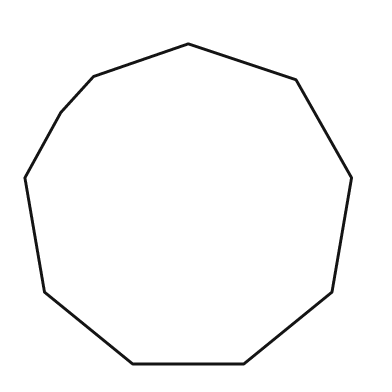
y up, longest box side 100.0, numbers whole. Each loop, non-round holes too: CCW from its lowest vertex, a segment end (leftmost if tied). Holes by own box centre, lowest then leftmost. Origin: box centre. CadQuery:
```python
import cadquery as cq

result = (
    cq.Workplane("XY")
    .moveTo(-17.0, -49.0)
    .lineTo(17.0, -49.0)
    .lineTo(44.0, -27.0)
    .lineTo(50.0, 8.0)
    .lineTo(33.0, 38.0)
    .lineTo(0.0, 49.0)
    .lineTo(-29.0, 39.0)
    .lineTo(-39.0, 28.0)
    .lineTo(-50.0, 8.0)
    .lineTo(-44.0, -27.0)
    .close()
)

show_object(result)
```